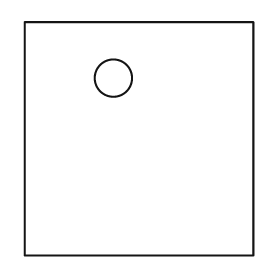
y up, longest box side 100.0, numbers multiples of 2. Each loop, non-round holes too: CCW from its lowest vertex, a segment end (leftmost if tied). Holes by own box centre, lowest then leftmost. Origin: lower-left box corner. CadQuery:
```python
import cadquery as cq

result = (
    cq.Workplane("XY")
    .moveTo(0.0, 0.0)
    .lineTo(98.0, 0.0)
    .lineTo(98.0, 100.0)
    .lineTo(0.0, 100.0)
    .close()
    .moveTo(38.0, 76.0)
    .circle(8.0)
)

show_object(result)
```